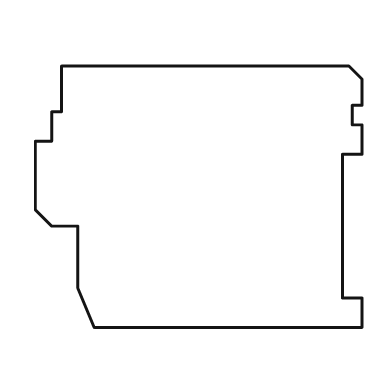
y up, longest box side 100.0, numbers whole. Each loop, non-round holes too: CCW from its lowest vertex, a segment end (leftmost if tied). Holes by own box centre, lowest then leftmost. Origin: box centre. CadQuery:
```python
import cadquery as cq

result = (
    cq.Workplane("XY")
    .moveTo(-32.0, -40.0)
    .lineTo(50.0, -40.0)
    .lineTo(50.0, -31.0)
    .lineTo(44.0, -31.0)
    .lineTo(44.0, 13.0)
    .lineTo(50.0, 13.0)
    .lineTo(50.0, 22.0)
    .lineTo(47.0, 22.0)
    .lineTo(47.0, 28.0)
    .lineTo(50.0, 28.0)
    .lineTo(50.0, 36.0)
    .lineTo(46.0, 40.0)
    .lineTo(-42.0, 40.0)
    .lineTo(-42.0, 26.0)
    .lineTo(-45.0, 26.0)
    .lineTo(-45.0, 17.0)
    .lineTo(-50.0, 17.0)
    .lineTo(-50.0, -4.0)
    .lineTo(-45.0, -9.0)
    .lineTo(-37.0, -9.0)
    .lineTo(-37.0, -28.0)
    .close()
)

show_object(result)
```